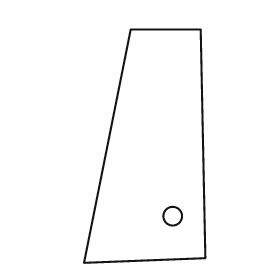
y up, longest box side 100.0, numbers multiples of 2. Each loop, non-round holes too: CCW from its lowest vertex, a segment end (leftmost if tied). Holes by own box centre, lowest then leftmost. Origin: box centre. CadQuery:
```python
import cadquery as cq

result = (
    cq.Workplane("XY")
    .moveTo(-26.0, -50.0)
    .lineTo(26.0, -48.0)
    .lineTo(24.0, 50.0)
    .lineTo(-6.0, 50.0)
    .close()
    .moveTo(12.0, -30.0)
    .circle(4.0)
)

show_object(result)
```